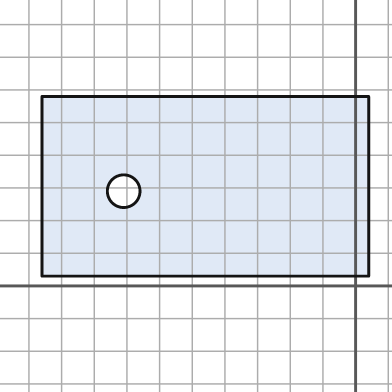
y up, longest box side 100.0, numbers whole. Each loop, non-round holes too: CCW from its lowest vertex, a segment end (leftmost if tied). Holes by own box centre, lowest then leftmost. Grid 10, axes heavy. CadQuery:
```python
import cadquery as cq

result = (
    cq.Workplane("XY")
    .moveTo(-96.0, 3.0)
    .lineTo(4.0, 3.0)
    .lineTo(4.0, 58.0)
    .lineTo(-96.0, 58.0)
    .close()
    .moveTo(-71.0, 29.0)
    .circle(5.0)
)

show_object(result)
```